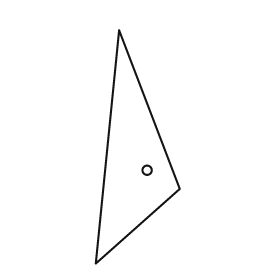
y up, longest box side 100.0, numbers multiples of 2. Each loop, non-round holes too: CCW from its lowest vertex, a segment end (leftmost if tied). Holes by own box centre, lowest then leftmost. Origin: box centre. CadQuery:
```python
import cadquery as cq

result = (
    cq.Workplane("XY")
    .moveTo(-18.0, -50.0)
    .lineTo(18.0, -18.0)
    .lineTo(-8.0, 50.0)
    .close()
    .moveTo(4.0, -10.0)
    .circle(2.0)
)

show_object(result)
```